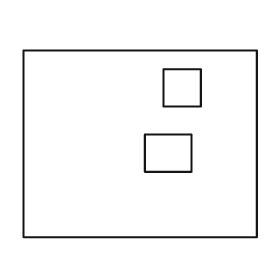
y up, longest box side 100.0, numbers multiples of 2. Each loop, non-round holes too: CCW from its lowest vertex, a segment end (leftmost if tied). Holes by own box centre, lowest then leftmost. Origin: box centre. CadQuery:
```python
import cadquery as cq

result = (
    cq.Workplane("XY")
    .moveTo(-50.0, -40.0)
    .lineTo(50.0, -40.0)
    .lineTo(50.0, 40.0)
    .lineTo(-50.0, 40.0)
    .close()
    .moveTo(2.0, -12.0)
    .lineTo(22.0, -12.0)
    .lineTo(22.0, 4.0)
    .lineTo(2.0, 4.0)
    .close()
    .moveTo(10.0, 16.0)
    .lineTo(26.0, 16.0)
    .lineTo(26.0, 32.0)
    .lineTo(10.0, 32.0)
    .close()
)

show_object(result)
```